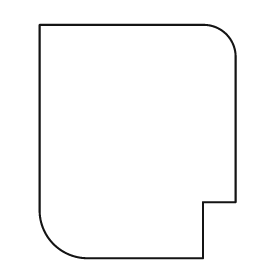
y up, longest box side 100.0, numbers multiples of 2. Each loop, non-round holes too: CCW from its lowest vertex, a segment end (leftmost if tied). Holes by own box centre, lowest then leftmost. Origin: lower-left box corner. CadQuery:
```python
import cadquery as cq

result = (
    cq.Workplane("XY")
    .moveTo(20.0, 0.0)
    .lineTo(70.0, 0.0)
    .lineTo(70.0, 24.0)
    .lineTo(84.0, 24.0)
    .lineTo(84.0, 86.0)
    .threePointArc((80.0, 96.0), (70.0, 100.0))
    .lineTo(0.0, 100.0)
    .lineTo(0.0, 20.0)
    .threePointArc((6.0, 6.0), (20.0, 0.0))
    .close()
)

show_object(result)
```